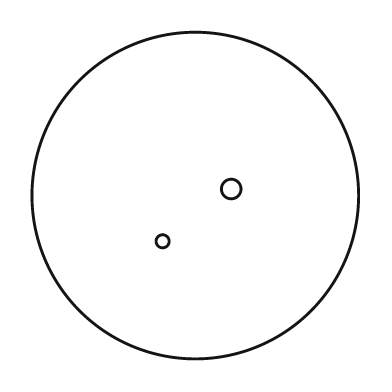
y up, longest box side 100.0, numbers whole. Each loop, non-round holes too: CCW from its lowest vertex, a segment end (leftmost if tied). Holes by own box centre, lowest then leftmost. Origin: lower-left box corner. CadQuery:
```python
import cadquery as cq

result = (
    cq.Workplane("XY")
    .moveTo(50.0, 50.0)
    .circle(50.0)
    .moveTo(40.0, 36.0)
    .circle(2.0)
    .moveTo(61.0, 52.0)
    .circle(3.0)
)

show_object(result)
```